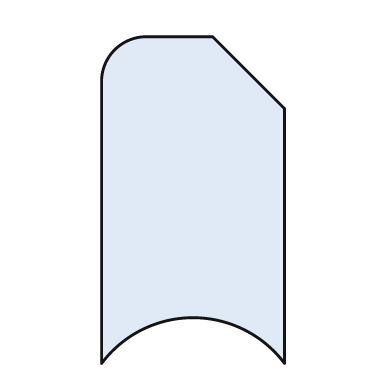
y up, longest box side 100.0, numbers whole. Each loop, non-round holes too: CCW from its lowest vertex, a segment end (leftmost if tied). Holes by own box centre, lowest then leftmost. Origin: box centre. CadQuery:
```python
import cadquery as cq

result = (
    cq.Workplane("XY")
    .moveTo(-28.0, -50.0)
    .threePointArc((0.0, -36.0), (28.0, -50.0))
    .lineTo(28.0, 28.0)
    .lineTo(6.0, 50.0)
    .lineTo(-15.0, 50.0)
    .threePointArc((-24.0, 46.0), (-28.0, 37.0))
    .close()
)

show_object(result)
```